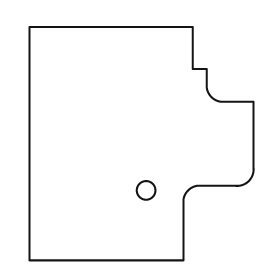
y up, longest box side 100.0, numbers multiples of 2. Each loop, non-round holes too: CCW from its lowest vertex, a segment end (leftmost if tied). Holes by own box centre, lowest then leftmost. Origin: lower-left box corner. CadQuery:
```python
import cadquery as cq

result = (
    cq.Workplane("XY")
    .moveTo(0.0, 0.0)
    .lineTo(66.0, 0.0)
    .lineTo(66.0, 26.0)
    .threePointArc((68.0, 30.0), (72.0, 32.0))
    .lineTo(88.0, 32.0)
    .threePointArc((94.0, 34.0), (96.0, 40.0))
    .lineTo(96.0, 68.0)
    .lineTo(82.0, 68.0)
    .threePointArc((78.0, 70.0), (76.0, 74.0))
    .lineTo(76.0, 82.0)
    .lineTo(70.0, 82.0)
    .lineTo(70.0, 100.0)
    .lineTo(0.0, 100.0)
    .close()
    .moveTo(50.0, 30.0)
    .circle(4.0)
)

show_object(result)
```